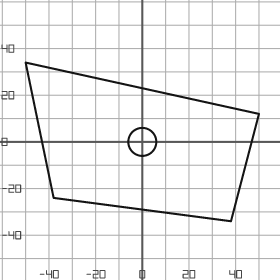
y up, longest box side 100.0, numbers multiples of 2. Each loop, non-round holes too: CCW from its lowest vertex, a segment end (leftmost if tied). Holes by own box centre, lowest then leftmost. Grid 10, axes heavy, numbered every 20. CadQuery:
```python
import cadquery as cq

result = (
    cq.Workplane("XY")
    .moveTo(38.0, -34.0)
    .lineTo(50.0, 12.0)
    .lineTo(-50.0, 34.0)
    .lineTo(-38.0, -24.0)
    .close()
    .moveTo(0.0, 0.0)
    .circle(6.0)
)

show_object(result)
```